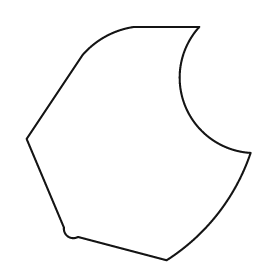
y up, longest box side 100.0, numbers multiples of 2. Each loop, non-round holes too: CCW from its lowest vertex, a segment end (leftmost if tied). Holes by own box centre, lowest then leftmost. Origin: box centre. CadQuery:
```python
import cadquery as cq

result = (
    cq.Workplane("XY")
    .moveTo(12.0, -50.0)
    .threePointArc((34.0, -30.0), (48.0, -4.0))
    .threePointArc((20.0, 16.0), (26.0, 50.0))
    .lineTo(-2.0, 50.0)
    .threePointArc((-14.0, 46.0), (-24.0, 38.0))
    .lineTo(-48.0, 2.0)
    .lineTo(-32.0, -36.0)
    .threePointArc((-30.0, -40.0), (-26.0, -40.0))
    .close()
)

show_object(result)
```